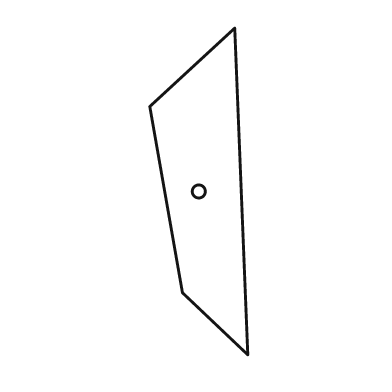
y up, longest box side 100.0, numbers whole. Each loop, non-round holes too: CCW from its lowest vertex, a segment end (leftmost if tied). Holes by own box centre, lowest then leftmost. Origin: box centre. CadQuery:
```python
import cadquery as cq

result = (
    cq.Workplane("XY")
    .moveTo(15.0, -50.0)
    .lineTo(11.0, 50.0)
    .lineTo(-15.0, 26.0)
    .lineTo(-5.0, -31.0)
    .close()
    .moveTo(0.0, 0.0)
    .circle(2.0)
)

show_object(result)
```